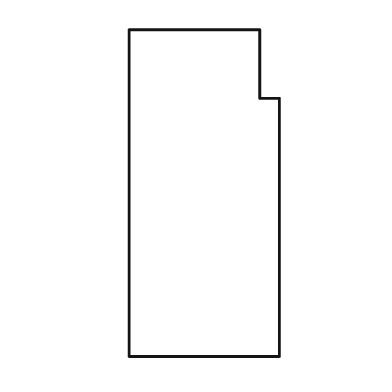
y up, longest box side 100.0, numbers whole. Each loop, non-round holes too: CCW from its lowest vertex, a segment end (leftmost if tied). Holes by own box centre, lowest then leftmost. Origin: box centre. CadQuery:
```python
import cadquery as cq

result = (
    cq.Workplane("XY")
    .moveTo(-23.0, -50.0)
    .lineTo(23.0, -50.0)
    .lineTo(23.0, 29.0)
    .lineTo(17.0, 29.0)
    .lineTo(17.0, 50.0)
    .lineTo(-23.0, 50.0)
    .close()
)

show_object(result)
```